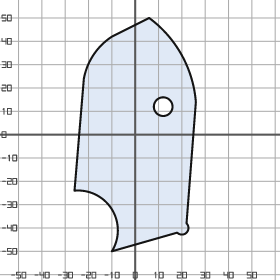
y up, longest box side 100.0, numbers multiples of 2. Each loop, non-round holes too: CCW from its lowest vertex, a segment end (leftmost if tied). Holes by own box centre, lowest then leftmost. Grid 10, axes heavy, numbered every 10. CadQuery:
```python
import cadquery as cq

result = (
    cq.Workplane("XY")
    .moveTo(-10.0, -50.0)
    .lineTo(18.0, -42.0)
    .threePointArc((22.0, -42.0), (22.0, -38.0))
    .lineTo(26.0, 14.0)
    .threePointArc((20.0, 34.0), (6.0, 50.0))
    .lineTo(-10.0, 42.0)
    .threePointArc((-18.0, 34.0), (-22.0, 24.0))
    .lineTo(-26.0, -24.0)
    .threePointArc((-10.0, -32.0), (-10.0, -50.0))
    .close()
    .moveTo(12.0, 12.0)
    .circle(4.0)
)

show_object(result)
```